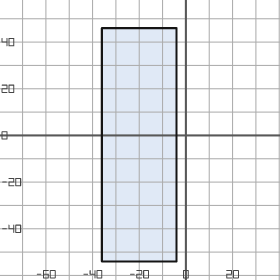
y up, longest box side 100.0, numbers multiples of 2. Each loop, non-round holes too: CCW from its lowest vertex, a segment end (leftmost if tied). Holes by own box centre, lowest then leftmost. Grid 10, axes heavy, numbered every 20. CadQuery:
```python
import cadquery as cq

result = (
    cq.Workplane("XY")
    .moveTo(-36.0, -54.0)
    .lineTo(-4.0, -54.0)
    .lineTo(-4.0, 46.0)
    .lineTo(-36.0, 46.0)
    .close()
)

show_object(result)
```